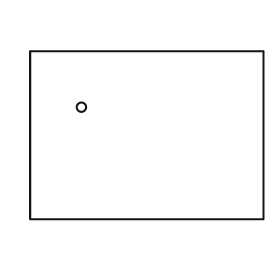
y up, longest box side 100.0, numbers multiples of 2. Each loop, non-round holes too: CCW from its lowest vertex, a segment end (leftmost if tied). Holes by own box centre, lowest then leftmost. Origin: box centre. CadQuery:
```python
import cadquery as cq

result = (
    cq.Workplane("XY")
    .moveTo(-50.0, -36.0)
    .lineTo(50.0, -36.0)
    .lineTo(50.0, 36.0)
    .lineTo(-50.0, 36.0)
    .close()
    .moveTo(-28.0, 12.0)
    .circle(2.0)
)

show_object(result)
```